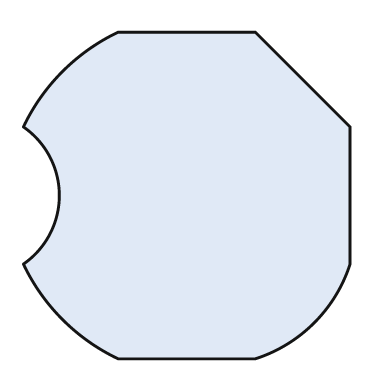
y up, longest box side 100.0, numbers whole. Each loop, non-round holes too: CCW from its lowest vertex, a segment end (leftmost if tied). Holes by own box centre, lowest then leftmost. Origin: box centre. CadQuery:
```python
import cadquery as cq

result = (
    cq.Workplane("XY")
    .moveTo(-21.0, -50.0)
    .lineTo(21.0, -50.0)
    .threePointArc((39.0, -39.0), (50.0, -21.0))
    .lineTo(50.0, 21.0)
    .lineTo(21.0, 50.0)
    .lineTo(-21.0, 50.0)
    .threePointArc((-38.0, 38.0), (-50.0, 21.0))
    .threePointArc((-39.0, 0.0), (-50.0, -21.0))
    .threePointArc((-38.0, -38.0), (-21.0, -50.0))
    .close()
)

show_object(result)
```